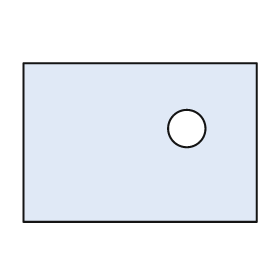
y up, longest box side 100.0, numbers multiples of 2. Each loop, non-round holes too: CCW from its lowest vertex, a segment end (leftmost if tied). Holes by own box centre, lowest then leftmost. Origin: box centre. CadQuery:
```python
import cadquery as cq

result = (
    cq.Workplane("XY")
    .moveTo(-50.0, -34.0)
    .lineTo(50.0, -34.0)
    .lineTo(50.0, 34.0)
    .lineTo(-50.0, 34.0)
    .close()
    .moveTo(20.0, 6.0)
    .circle(8.0)
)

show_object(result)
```